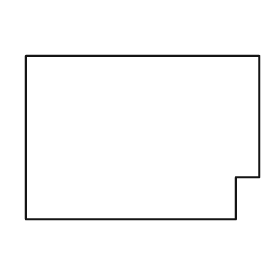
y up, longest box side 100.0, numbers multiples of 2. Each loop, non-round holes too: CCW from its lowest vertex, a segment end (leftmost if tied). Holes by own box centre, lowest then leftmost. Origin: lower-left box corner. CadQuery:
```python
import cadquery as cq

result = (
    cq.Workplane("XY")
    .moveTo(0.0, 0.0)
    .lineTo(90.0, 0.0)
    .lineTo(90.0, 18.0)
    .lineTo(100.0, 18.0)
    .lineTo(100.0, 70.0)
    .lineTo(0.0, 70.0)
    .close()
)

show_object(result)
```